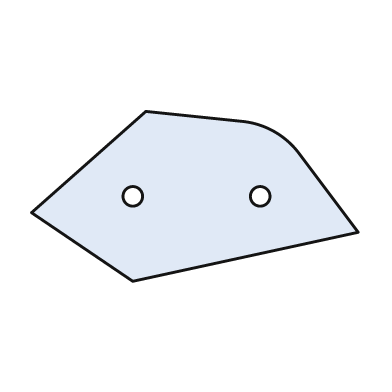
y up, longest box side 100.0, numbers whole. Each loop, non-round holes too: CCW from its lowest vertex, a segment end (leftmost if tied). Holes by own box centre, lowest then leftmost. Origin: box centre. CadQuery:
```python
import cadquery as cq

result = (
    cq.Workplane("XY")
    .moveTo(-19.0, -26.0)
    .lineTo(50.0, -11.0)
    .lineTo(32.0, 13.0)
    .threePointArc((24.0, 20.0), (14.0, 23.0))
    .lineTo(-15.0, 26.0)
    .lineTo(-50.0, -5.0)
    .close()
    .moveTo(-19.0, 0.0)
    .circle(3.0)
    .moveTo(20.0, 0.0)
    .circle(3.0)
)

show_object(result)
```